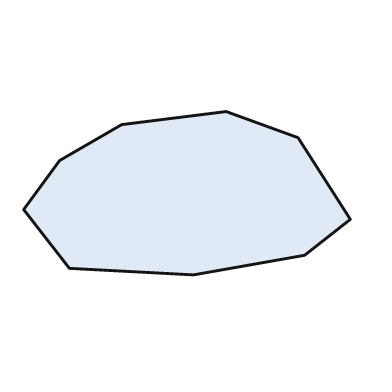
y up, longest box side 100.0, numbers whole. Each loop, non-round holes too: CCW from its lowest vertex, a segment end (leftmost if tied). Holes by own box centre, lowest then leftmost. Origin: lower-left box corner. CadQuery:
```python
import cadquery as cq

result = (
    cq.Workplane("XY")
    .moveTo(52.0, 0.0)
    .lineTo(86.0, 6.0)
    .lineTo(100.0, 17.0)
    .lineTo(84.0, 42.0)
    .lineTo(62.0, 50.0)
    .lineTo(30.0, 46.0)
    .lineTo(11.0, 35.0)
    .lineTo(0.0, 20.0)
    .lineTo(14.0, 2.0)
    .close()
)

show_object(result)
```